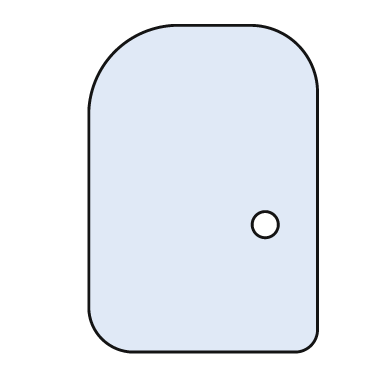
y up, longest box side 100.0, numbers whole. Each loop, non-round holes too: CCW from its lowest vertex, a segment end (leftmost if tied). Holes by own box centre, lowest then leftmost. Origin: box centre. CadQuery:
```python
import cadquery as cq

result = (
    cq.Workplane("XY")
    .moveTo(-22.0, -50.0)
    .lineTo(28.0, -50.0)
    .threePointArc((33.0, -48.0), (35.0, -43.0))
    .lineTo(35.0, 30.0)
    .threePointArc((29.0, 44.0), (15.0, 50.0))
    .lineTo(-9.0, 50.0)
    .threePointArc((-27.0, 42.0), (-35.0, 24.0))
    .lineTo(-35.0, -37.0)
    .threePointArc((-31.0, -46.0), (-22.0, -50.0))
    .close()
    .moveTo(19.0, -11.0)
    .circle(4.0)
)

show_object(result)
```